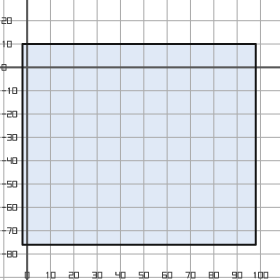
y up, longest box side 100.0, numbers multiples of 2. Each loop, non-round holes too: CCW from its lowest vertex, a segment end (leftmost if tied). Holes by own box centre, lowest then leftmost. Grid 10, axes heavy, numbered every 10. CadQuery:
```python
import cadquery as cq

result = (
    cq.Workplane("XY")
    .moveTo(-2.0, -76.0)
    .lineTo(98.0, -76.0)
    .lineTo(98.0, 10.0)
    .lineTo(-2.0, 10.0)
    .close()
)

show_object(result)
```